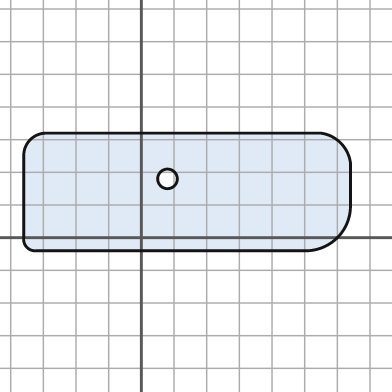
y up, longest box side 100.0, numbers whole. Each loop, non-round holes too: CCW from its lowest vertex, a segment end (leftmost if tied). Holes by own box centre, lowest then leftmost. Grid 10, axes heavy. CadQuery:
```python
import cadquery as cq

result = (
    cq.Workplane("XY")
    .moveTo(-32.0, -4.0)
    .lineTo(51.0, -4.0)
    .threePointArc((60.0, 0.0), (64.0, 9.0))
    .lineTo(64.0, 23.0)
    .threePointArc((61.0, 29.0), (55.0, 32.0))
    .lineTo(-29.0, 32.0)
    .threePointArc((-34.0, 30.0), (-36.0, 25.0))
    .lineTo(-36.0, 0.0)
    .threePointArc((-35.0, -3.0), (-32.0, -4.0))
    .close()
    .moveTo(8.0, 18.0)
    .circle(3.0)
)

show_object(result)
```